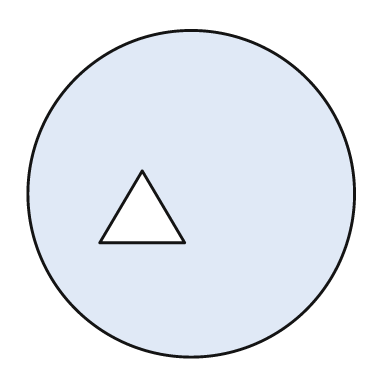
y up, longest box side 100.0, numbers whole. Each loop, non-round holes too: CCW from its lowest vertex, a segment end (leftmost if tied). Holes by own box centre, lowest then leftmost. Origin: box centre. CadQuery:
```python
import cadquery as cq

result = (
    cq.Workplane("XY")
    .moveTo(0.0, 0.0)
    .circle(50.0)
    .moveTo(-28.0, -15.0)
    .lineTo(-2.0, -15.0)
    .lineTo(-15.0, 7.0)
    .close()
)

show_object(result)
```